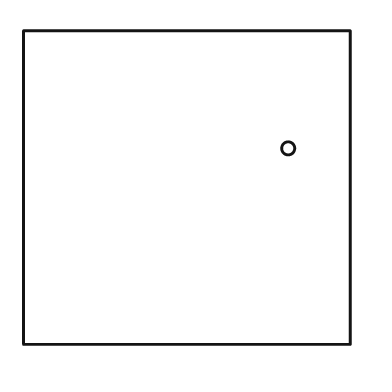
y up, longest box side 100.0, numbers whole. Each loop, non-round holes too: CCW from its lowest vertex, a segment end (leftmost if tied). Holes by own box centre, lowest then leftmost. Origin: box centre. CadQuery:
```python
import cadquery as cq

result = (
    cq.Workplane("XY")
    .moveTo(-50.0, -48.0)
    .lineTo(50.0, -48.0)
    .lineTo(50.0, 48.0)
    .lineTo(-50.0, 48.0)
    .close()
    .moveTo(31.0, 12.0)
    .circle(2.0)
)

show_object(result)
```